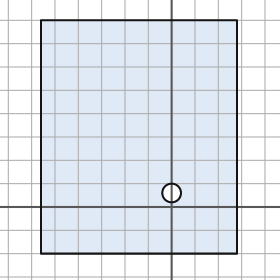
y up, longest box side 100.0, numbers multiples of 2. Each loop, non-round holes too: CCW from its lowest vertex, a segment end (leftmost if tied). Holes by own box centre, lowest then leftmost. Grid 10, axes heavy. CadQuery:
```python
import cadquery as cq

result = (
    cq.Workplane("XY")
    .moveTo(-56.0, -20.0)
    .lineTo(28.0, -20.0)
    .lineTo(28.0, 80.0)
    .lineTo(-56.0, 80.0)
    .close()
    .moveTo(0.0, 6.0)
    .circle(4.0)
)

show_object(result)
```